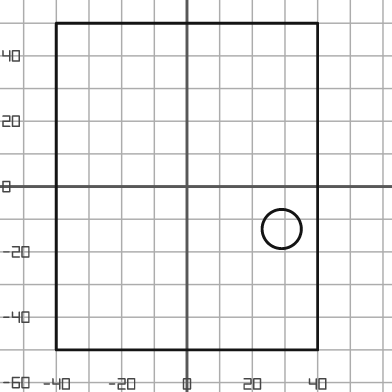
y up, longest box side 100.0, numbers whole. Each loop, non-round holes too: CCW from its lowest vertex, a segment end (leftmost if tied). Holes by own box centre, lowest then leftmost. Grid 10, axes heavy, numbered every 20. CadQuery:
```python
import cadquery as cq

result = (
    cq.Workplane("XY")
    .moveTo(-40.0, -50.0)
    .lineTo(40.0, -50.0)
    .lineTo(40.0, 50.0)
    .lineTo(-40.0, 50.0)
    .close()
    .moveTo(29.0, -13.0)
    .circle(6.0)
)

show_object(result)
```